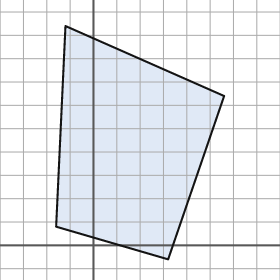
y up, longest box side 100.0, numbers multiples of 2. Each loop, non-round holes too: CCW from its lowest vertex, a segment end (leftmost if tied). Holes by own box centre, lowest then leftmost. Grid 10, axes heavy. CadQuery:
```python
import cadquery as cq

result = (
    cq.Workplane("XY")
    .moveTo(32.0, -6.0)
    .lineTo(56.0, 64.0)
    .lineTo(-12.0, 94.0)
    .lineTo(-16.0, 8.0)
    .close()
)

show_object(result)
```